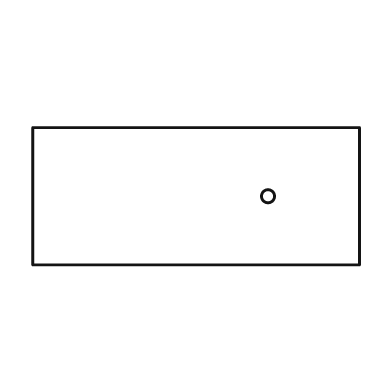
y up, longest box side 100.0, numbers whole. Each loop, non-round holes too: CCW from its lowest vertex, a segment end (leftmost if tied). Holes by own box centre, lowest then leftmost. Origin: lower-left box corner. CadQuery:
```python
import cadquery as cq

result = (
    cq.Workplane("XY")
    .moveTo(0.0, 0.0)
    .lineTo(100.0, 0.0)
    .lineTo(100.0, 42.0)
    .lineTo(0.0, 42.0)
    .close()
    .moveTo(72.0, 21.0)
    .circle(2.0)
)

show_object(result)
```